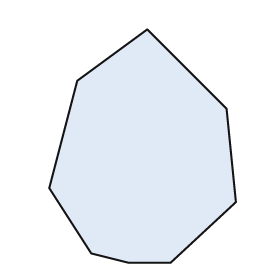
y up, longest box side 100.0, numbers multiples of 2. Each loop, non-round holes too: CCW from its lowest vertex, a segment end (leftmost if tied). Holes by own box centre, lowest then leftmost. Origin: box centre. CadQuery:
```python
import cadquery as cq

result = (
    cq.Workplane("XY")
    .moveTo(-6.0, -50.0)
    .lineTo(12.0, -50.0)
    .lineTo(40.0, -24.0)
    .lineTo(36.0, 16.0)
    .lineTo(2.0, 50.0)
    .lineTo(-28.0, 28.0)
    .lineTo(-40.0, -18.0)
    .lineTo(-22.0, -46.0)
    .close()
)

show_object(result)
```